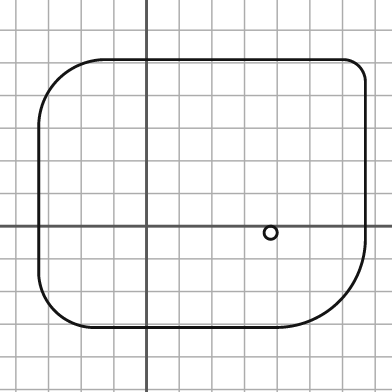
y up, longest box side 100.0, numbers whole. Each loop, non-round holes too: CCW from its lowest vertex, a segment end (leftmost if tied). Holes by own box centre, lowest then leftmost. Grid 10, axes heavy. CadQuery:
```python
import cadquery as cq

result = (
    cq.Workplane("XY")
    .moveTo(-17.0, -31.0)
    .lineTo(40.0, -31.0)
    .threePointArc((59.0, -23.0), (67.0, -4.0))
    .lineTo(67.0, 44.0)
    .threePointArc((65.0, 49.0), (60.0, 51.0))
    .lineTo(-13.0, 51.0)
    .threePointArc((-27.0, 45.0), (-33.0, 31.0))
    .lineTo(-33.0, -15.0)
    .threePointArc((-28.0, -26.0), (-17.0, -31.0))
    .close()
    .moveTo(38.0, -2.0)
    .circle(2.0)
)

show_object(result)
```